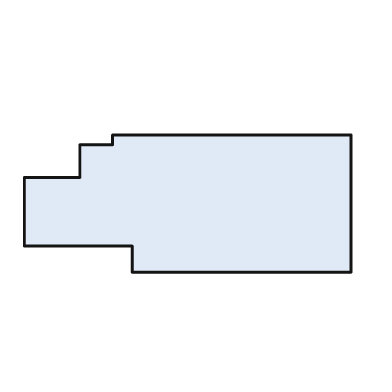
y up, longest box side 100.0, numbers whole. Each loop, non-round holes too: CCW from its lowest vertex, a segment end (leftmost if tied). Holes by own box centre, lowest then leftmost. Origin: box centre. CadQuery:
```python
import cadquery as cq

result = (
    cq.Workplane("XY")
    .moveTo(-17.0, -21.0)
    .lineTo(50.0, -21.0)
    .lineTo(50.0, 21.0)
    .lineTo(-23.0, 21.0)
    .lineTo(-23.0, 18.0)
    .lineTo(-33.0, 18.0)
    .lineTo(-33.0, 8.0)
    .lineTo(-50.0, 8.0)
    .lineTo(-50.0, -13.0)
    .lineTo(-17.0, -13.0)
    .close()
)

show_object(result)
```